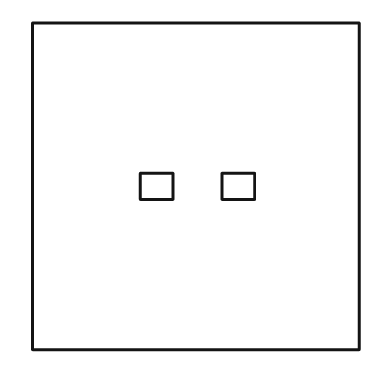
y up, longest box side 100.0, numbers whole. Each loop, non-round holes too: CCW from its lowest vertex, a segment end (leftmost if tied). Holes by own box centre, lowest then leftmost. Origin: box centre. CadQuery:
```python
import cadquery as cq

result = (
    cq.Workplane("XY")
    .moveTo(-50.0, -50.0)
    .lineTo(50.0, -50.0)
    .lineTo(50.0, 50.0)
    .lineTo(-50.0, 50.0)
    .close()
    .moveTo(-17.0, -4.0)
    .lineTo(-7.0, -4.0)
    .lineTo(-7.0, 4.0)
    .lineTo(-17.0, 4.0)
    .close()
    .moveTo(8.0, -4.0)
    .lineTo(18.0, -4.0)
    .lineTo(18.0, 4.0)
    .lineTo(8.0, 4.0)
    .close()
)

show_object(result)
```